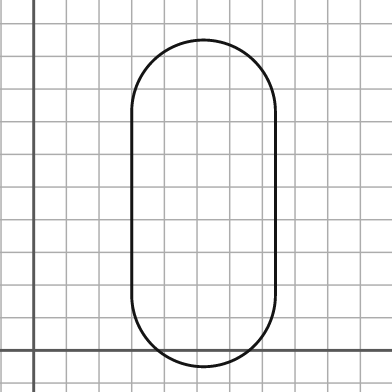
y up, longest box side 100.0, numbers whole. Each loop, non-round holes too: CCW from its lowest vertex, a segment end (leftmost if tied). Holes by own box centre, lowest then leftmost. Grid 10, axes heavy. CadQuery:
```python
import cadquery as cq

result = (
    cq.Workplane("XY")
    .moveTo(30.0, 17.0)
    .threePointArc((52.0, -5.0), (74.0, 17.0))
    .lineTo(74.0, 73.0)
    .threePointArc((52.0, 95.0), (30.0, 73.0))
    .close()
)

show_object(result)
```